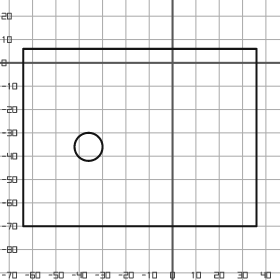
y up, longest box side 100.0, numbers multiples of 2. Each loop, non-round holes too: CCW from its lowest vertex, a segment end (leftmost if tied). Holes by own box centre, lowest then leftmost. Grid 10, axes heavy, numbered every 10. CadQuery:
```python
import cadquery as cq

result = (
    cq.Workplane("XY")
    .moveTo(-64.0, -70.0)
    .lineTo(36.0, -70.0)
    .lineTo(36.0, 6.0)
    .lineTo(-64.0, 6.0)
    .close()
    .moveTo(-36.0, -36.0)
    .circle(6.0)
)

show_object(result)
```